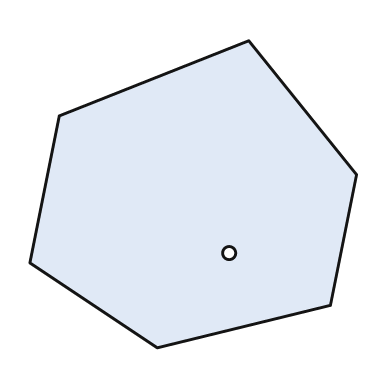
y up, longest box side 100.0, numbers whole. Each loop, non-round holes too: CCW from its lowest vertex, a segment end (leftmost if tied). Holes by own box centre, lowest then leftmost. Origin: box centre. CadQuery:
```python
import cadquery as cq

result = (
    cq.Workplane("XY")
    .moveTo(-11.0, -47.0)
    .lineTo(42.0, -34.0)
    .lineTo(50.0, 6.0)
    .lineTo(17.0, 47.0)
    .lineTo(-41.0, 24.0)
    .lineTo(-50.0, -21.0)
    .close()
    .moveTo(11.0, -18.0)
    .circle(2.0)
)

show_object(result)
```